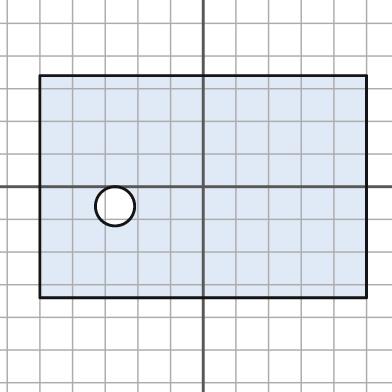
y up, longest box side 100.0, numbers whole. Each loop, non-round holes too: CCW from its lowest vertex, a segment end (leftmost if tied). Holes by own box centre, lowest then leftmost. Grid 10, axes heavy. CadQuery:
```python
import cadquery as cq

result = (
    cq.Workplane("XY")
    .moveTo(-50.0, -34.0)
    .lineTo(50.0, -34.0)
    .lineTo(50.0, 34.0)
    .lineTo(-50.0, 34.0)
    .close()
    .moveTo(-27.0, -6.0)
    .circle(6.0)
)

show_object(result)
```